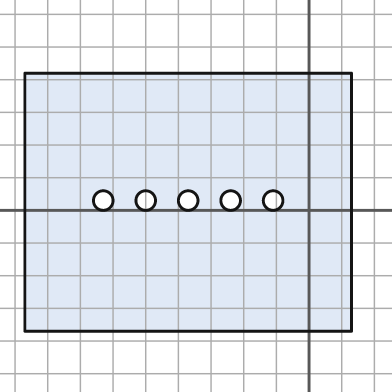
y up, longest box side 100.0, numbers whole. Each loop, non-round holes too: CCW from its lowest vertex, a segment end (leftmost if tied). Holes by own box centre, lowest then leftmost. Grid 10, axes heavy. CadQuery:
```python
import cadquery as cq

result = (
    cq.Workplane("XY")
    .moveTo(-87.0, -37.0)
    .lineTo(13.0, -37.0)
    .lineTo(13.0, 42.0)
    .lineTo(-87.0, 42.0)
    .close()
    .moveTo(-63.0, 3.0)
    .circle(3.0)
    .moveTo(-50.0, 3.0)
    .circle(3.0)
    .moveTo(-37.0, 3.0)
    .circle(3.0)
    .moveTo(-24.0, 3.0)
    .circle(3.0)
    .moveTo(-11.0, 3.0)
    .circle(3.0)
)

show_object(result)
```